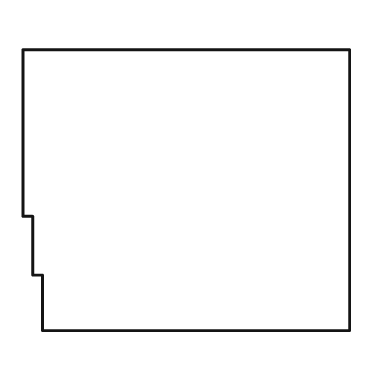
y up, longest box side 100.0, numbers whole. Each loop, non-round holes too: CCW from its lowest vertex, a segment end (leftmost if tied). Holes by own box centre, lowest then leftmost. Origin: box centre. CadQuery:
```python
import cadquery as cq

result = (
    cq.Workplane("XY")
    .moveTo(-44.0, -43.0)
    .lineTo(50.0, -43.0)
    .lineTo(50.0, 43.0)
    .lineTo(-50.0, 43.0)
    .lineTo(-50.0, -8.0)
    .lineTo(-47.0, -8.0)
    .lineTo(-47.0, -26.0)
    .lineTo(-44.0, -26.0)
    .close()
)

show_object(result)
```